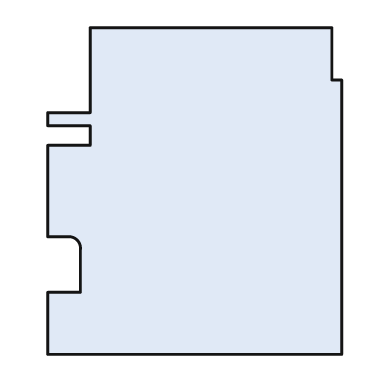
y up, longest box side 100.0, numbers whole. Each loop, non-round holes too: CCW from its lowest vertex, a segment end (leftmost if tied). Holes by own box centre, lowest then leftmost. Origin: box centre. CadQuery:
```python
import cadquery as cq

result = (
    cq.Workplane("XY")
    .moveTo(-45.0, -50.0)
    .lineTo(45.0, -50.0)
    .lineTo(45.0, 34.0)
    .lineTo(42.0, 34.0)
    .lineTo(42.0, 50.0)
    .lineTo(-32.0, 50.0)
    .lineTo(-32.0, 24.0)
    .lineTo(-45.0, 24.0)
    .lineTo(-45.0, 20.0)
    .lineTo(-32.0, 20.0)
    .lineTo(-32.0, 14.0)
    .lineTo(-45.0, 14.0)
    .lineTo(-45.0, -14.0)
    .lineTo(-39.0, -14.0)
    .threePointArc((-36.0, -15.0), (-35.0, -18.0))
    .lineTo(-35.0, -31.0)
    .lineTo(-45.0, -31.0)
    .close()
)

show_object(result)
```